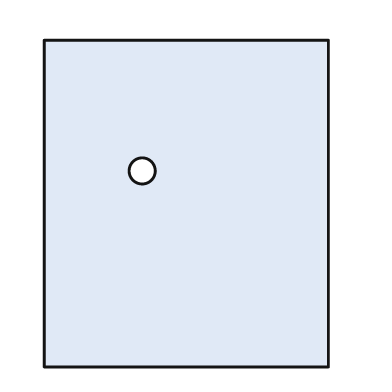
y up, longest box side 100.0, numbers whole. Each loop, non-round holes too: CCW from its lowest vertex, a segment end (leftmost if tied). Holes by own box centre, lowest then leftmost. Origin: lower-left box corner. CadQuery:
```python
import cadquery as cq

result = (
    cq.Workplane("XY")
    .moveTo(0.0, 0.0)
    .lineTo(87.0, 0.0)
    .lineTo(87.0, 100.0)
    .lineTo(0.0, 100.0)
    .close()
    .moveTo(30.0, 60.0)
    .circle(4.0)
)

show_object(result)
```